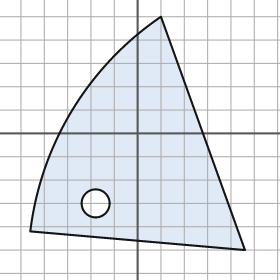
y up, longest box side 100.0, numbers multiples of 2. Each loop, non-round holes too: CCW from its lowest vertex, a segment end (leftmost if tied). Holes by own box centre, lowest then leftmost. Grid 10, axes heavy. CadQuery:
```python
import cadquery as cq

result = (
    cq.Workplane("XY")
    .moveTo(46.0, -50.0)
    .lineTo(10.0, 50.0)
    .threePointArc((-28.0, 10.0), (-46.0, -42.0))
    .close()
    .moveTo(-18.0, -30.0)
    .circle(6.0)
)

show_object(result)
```